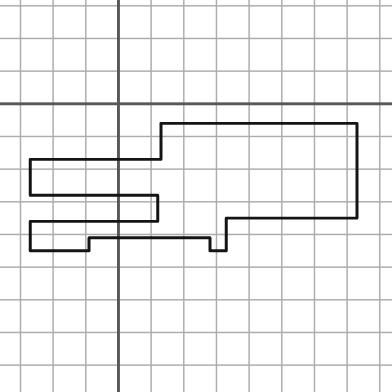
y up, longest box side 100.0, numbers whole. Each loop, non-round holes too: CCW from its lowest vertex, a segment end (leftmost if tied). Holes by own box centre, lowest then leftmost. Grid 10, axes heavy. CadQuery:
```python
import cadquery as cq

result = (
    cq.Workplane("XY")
    .moveTo(-27.0, -45.0)
    .lineTo(-9.0, -45.0)
    .lineTo(-9.0, -41.0)
    .lineTo(28.0, -41.0)
    .lineTo(28.0, -45.0)
    .lineTo(33.0, -45.0)
    .lineTo(33.0, -35.0)
    .lineTo(73.0, -35.0)
    .lineTo(73.0, -6.0)
    .lineTo(13.0, -6.0)
    .lineTo(13.0, -17.0)
    .lineTo(-27.0, -17.0)
    .lineTo(-27.0, -28.0)
    .lineTo(12.0, -28.0)
    .lineTo(12.0, -36.0)
    .lineTo(-27.0, -36.0)
    .close()
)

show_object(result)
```